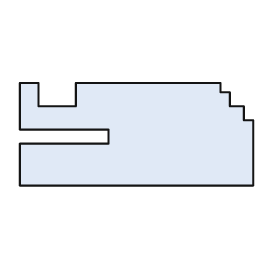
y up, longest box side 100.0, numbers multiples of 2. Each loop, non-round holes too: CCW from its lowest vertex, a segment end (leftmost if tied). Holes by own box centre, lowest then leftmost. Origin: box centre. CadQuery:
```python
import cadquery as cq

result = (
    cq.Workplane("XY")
    .moveTo(-50.0, -22.0)
    .lineTo(50.0, -22.0)
    .lineTo(50.0, 6.0)
    .lineTo(46.0, 6.0)
    .lineTo(46.0, 12.0)
    .lineTo(40.0, 12.0)
    .lineTo(40.0, 18.0)
    .lineTo(36.0, 18.0)
    .lineTo(36.0, 22.0)
    .lineTo(-26.0, 22.0)
    .lineTo(-26.0, 12.0)
    .lineTo(-42.0, 12.0)
    .lineTo(-42.0, 22.0)
    .lineTo(-50.0, 22.0)
    .lineTo(-50.0, 2.0)
    .lineTo(-12.0, 2.0)
    .lineTo(-12.0, -4.0)
    .lineTo(-50.0, -4.0)
    .close()
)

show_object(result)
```